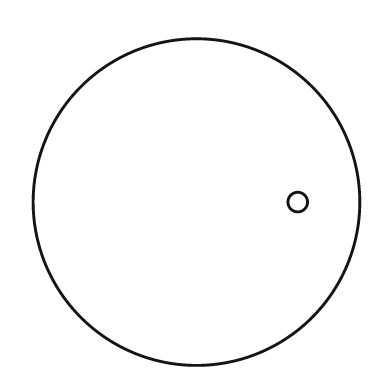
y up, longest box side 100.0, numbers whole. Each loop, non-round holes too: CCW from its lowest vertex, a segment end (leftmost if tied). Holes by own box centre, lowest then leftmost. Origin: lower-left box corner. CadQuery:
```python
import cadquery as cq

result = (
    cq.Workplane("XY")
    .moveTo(50.0, 50.0)
    .circle(50.0)
    .moveTo(81.0, 50.0)
    .circle(3.0)
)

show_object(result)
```